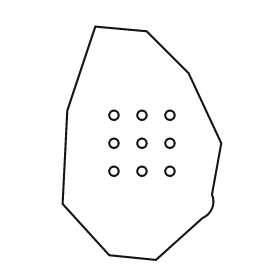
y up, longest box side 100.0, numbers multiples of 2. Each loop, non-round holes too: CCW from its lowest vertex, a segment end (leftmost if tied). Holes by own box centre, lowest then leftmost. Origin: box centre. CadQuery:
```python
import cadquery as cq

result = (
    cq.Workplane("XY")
    .moveTo(6.0, -50.0)
    .lineTo(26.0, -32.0)
    .threePointArc((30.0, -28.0), (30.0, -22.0))
    .lineTo(34.0, 0.0)
    .lineTo(20.0, 30.0)
    .lineTo(2.0, 48.0)
    .lineTo(-20.0, 50.0)
    .lineTo(-32.0, 14.0)
    .lineTo(-34.0, -26.0)
    .lineTo(-14.0, -48.0)
    .close()
    .moveTo(-12.0, -12.0)
    .circle(2.0)
    .moveTo(0.0, -12.0)
    .circle(2.0)
    .moveTo(12.0, -12.0)
    .circle(2.0)
    .moveTo(-12.0, 0.0)
    .circle(2.0)
    .moveTo(0.0, 0.0)
    .circle(2.0)
    .moveTo(12.0, 0.0)
    .circle(2.0)
    .moveTo(-12.0, 12.0)
    .circle(2.0)
    .moveTo(0.0, 12.0)
    .circle(2.0)
    .moveTo(12.0, 12.0)
    .circle(2.0)
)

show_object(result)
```